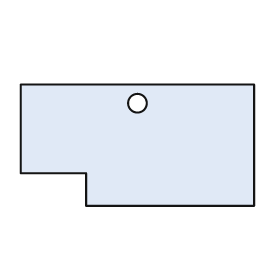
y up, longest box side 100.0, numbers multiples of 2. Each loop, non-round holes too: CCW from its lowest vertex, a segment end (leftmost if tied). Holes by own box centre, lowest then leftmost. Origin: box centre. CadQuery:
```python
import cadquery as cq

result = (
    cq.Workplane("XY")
    .moveTo(-22.0, -26.0)
    .lineTo(50.0, -26.0)
    .lineTo(50.0, 26.0)
    .lineTo(-50.0, 26.0)
    .lineTo(-50.0, -12.0)
    .lineTo(-22.0, -12.0)
    .close()
    .moveTo(0.0, 18.0)
    .circle(4.0)
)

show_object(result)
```